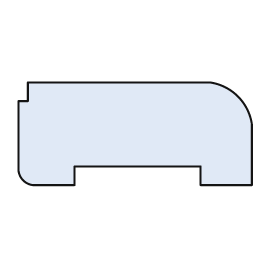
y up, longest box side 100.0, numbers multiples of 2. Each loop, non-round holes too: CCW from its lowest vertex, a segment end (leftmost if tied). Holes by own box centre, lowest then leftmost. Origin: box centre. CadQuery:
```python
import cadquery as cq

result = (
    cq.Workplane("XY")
    .moveTo(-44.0, -22.0)
    .lineTo(-26.0, -22.0)
    .lineTo(-26.0, -14.0)
    .lineTo(28.0, -14.0)
    .lineTo(28.0, -22.0)
    .lineTo(50.0, -22.0)
    .lineTo(50.0, 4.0)
    .threePointArc((44.0, 16.0), (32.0, 22.0))
    .lineTo(-46.0, 22.0)
    .lineTo(-46.0, 14.0)
    .lineTo(-50.0, 14.0)
    .lineTo(-50.0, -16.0)
    .threePointArc((-48.0, -20.0), (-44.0, -22.0))
    .close()
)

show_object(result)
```